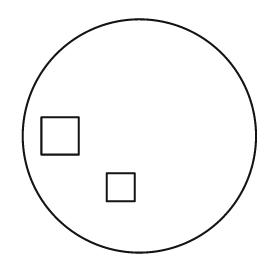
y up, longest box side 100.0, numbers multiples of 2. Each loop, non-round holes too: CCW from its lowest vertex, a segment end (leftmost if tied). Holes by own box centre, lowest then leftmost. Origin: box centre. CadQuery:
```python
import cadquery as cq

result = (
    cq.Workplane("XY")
    .moveTo(0.0, 0.0)
    .circle(50.0)
    .moveTo(-14.0, -28.0)
    .lineTo(-2.0, -28.0)
    .lineTo(-2.0, -16.0)
    .lineTo(-14.0, -16.0)
    .close()
    .moveTo(-42.0, -8.0)
    .lineTo(-26.0, -8.0)
    .lineTo(-26.0, 8.0)
    .lineTo(-42.0, 8.0)
    .close()
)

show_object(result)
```